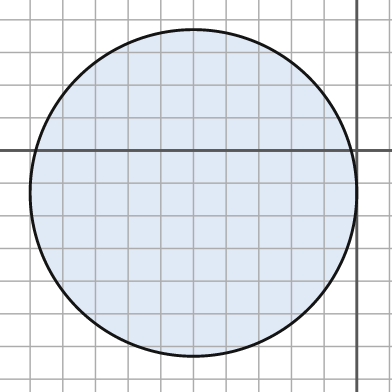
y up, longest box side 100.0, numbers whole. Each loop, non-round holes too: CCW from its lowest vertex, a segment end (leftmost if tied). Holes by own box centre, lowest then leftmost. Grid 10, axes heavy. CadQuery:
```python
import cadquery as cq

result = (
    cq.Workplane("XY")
    .moveTo(-50.0, -13.0)
    .circle(50.0)
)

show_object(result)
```